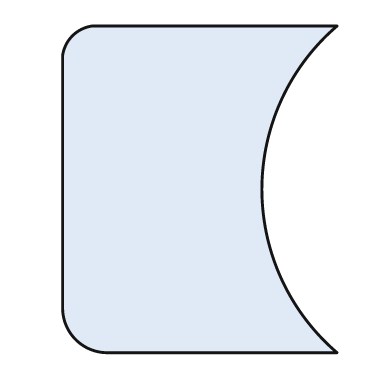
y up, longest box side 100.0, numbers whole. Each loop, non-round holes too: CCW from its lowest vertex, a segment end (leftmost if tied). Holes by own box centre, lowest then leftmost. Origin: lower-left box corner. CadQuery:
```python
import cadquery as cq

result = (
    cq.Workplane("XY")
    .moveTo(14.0, 0.0)
    .lineTo(84.0, 0.0)
    .threePointArc((61.0, 50.0), (84.0, 100.0))
    .lineTo(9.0, 100.0)
    .threePointArc((3.0, 97.0), (0.0, 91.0))
    .lineTo(0.0, 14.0)
    .threePointArc((4.0, 4.0), (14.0, 0.0))
    .close()
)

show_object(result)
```